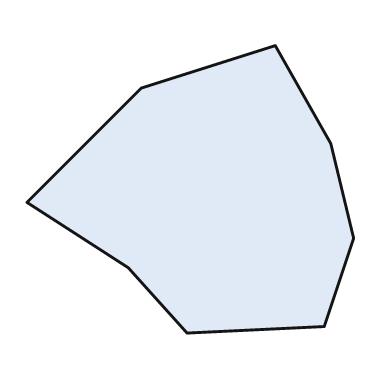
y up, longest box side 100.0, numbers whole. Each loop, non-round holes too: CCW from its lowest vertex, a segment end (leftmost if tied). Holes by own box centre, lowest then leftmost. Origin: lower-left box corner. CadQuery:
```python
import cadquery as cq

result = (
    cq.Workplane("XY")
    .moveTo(49.0, 0.0)
    .lineTo(91.0, 2.0)
    .lineTo(100.0, 29.0)
    .lineTo(93.0, 58.0)
    .lineTo(76.0, 88.0)
    .lineTo(35.0, 75.0)
    .lineTo(0.0, 40.0)
    .lineTo(31.0, 20.0)
    .close()
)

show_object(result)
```